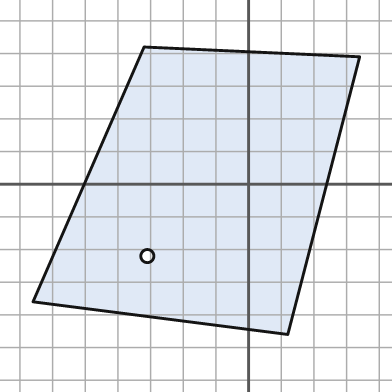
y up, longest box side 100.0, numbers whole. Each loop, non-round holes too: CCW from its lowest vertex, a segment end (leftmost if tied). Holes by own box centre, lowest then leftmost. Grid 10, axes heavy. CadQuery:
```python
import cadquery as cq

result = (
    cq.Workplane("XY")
    .moveTo(12.0, -46.0)
    .lineTo(34.0, 39.0)
    .lineTo(-32.0, 42.0)
    .lineTo(-66.0, -36.0)
    .close()
    .moveTo(-31.0, -22.0)
    .circle(2.0)
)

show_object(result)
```